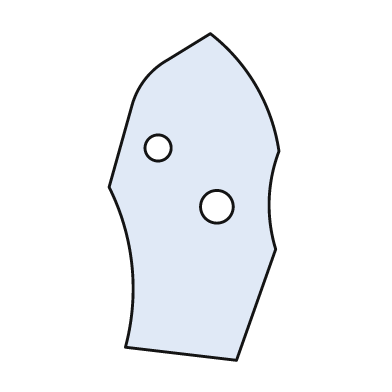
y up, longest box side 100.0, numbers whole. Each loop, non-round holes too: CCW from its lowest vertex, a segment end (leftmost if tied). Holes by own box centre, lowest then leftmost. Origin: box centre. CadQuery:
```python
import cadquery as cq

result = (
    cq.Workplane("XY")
    .moveTo(13.0, -50.0)
    .lineTo(25.0, -16.0)
    .threePointArc((23.0, -1.0), (26.0, 14.0))
    .threePointArc((19.0, 34.0), (5.0, 50.0))
    .lineTo(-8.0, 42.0)
    .threePointArc((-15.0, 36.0), (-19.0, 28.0))
    .lineTo(-26.0, 3.0)
    .threePointArc((-19.0, -21.0), (-21.0, -46.0))
    .close()
    .moveTo(7.0, -3.0)
    .circle(5.0)
    .moveTo(-11.0, 15.0)
    .circle(4.0)
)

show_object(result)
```